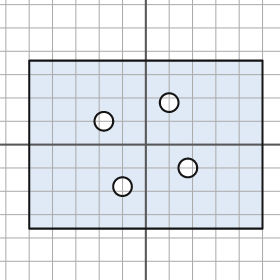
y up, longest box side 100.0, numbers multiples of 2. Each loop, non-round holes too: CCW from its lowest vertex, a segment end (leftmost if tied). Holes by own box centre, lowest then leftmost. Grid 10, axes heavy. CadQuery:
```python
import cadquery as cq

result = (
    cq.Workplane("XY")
    .moveTo(-50.0, -36.0)
    .lineTo(50.0, -36.0)
    .lineTo(50.0, 36.0)
    .lineTo(-50.0, 36.0)
    .close()
    .moveTo(-10.0, -18.0)
    .circle(4.0)
    .moveTo(18.0, -10.0)
    .circle(4.0)
    .moveTo(-18.0, 10.0)
    .circle(4.0)
    .moveTo(10.0, 18.0)
    .circle(4.0)
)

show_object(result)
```